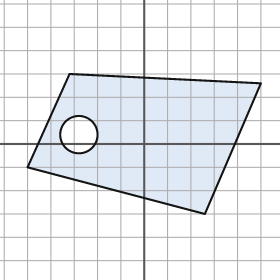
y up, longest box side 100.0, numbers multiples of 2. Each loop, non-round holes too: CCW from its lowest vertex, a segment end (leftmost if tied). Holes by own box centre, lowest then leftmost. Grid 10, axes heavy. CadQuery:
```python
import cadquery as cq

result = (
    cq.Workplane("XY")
    .moveTo(26.0, -30.0)
    .lineTo(50.0, 26.0)
    .lineTo(-32.0, 30.0)
    .lineTo(-50.0, -10.0)
    .close()
    .moveTo(-28.0, 4.0)
    .circle(8.0)
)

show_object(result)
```